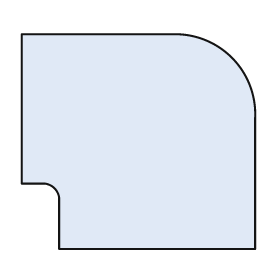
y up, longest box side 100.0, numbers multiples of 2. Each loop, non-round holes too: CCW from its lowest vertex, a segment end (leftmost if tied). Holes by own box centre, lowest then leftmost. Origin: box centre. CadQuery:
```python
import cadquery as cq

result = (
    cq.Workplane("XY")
    .moveTo(-34.0, -46.0)
    .lineTo(50.0, -46.0)
    .lineTo(50.0, 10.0)
    .threePointArc((40.0, 36.0), (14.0, 46.0))
    .lineTo(-50.0, 46.0)
    .lineTo(-50.0, -18.0)
    .lineTo(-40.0, -18.0)
    .threePointArc((-36.0, -20.0), (-34.0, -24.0))
    .close()
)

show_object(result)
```